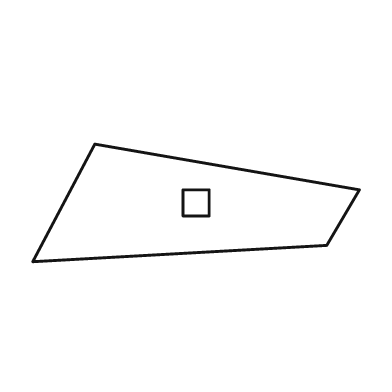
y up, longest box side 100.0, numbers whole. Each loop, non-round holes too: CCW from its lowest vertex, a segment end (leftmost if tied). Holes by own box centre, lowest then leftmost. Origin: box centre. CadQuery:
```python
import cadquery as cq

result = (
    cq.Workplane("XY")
    .moveTo(-50.0, -18.0)
    .lineTo(40.0, -13.0)
    .lineTo(50.0, 4.0)
    .lineTo(-31.0, 18.0)
    .close()
    .moveTo(-4.0, -4.0)
    .lineTo(4.0, -4.0)
    .lineTo(4.0, 4.0)
    .lineTo(-4.0, 4.0)
    .close()
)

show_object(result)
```